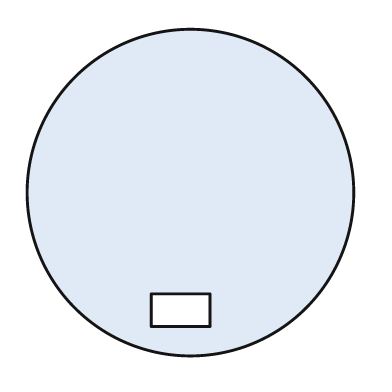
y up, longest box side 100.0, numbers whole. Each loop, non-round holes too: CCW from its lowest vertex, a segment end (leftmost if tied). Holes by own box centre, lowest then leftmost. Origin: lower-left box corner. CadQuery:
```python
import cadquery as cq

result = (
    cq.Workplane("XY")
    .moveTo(50.0, 50.0)
    .circle(50.0)
    .moveTo(38.0, 9.0)
    .lineTo(56.0, 9.0)
    .lineTo(56.0, 19.0)
    .lineTo(38.0, 19.0)
    .close()
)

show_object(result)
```